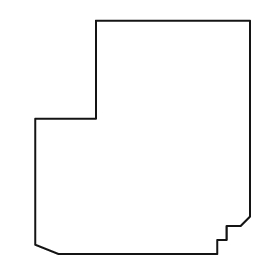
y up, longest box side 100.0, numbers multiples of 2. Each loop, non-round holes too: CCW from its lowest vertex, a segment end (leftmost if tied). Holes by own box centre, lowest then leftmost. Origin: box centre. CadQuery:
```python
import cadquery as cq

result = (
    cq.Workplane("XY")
    .moveTo(-36.0, -50.0)
    .lineTo(32.0, -50.0)
    .lineTo(32.0, -44.0)
    .lineTo(36.0, -44.0)
    .lineTo(36.0, -38.0)
    .lineTo(42.0, -38.0)
    .lineTo(46.0, -34.0)
    .lineTo(46.0, 50.0)
    .lineTo(-20.0, 50.0)
    .lineTo(-20.0, 8.0)
    .lineTo(-46.0, 8.0)
    .lineTo(-46.0, -46.0)
    .close()
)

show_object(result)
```